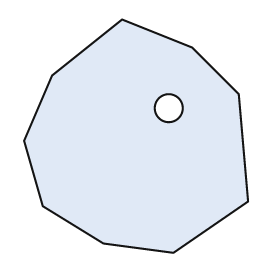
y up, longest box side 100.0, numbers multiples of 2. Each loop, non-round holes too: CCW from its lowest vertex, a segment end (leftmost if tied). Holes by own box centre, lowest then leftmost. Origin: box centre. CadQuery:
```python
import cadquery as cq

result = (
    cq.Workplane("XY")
    .moveTo(16.0, -50.0)
    .lineTo(48.0, -28.0)
    .lineTo(44.0, 18.0)
    .lineTo(24.0, 38.0)
    .lineTo(-6.0, 50.0)
    .lineTo(-36.0, 26.0)
    .lineTo(-48.0, -2.0)
    .lineTo(-40.0, -30.0)
    .lineTo(-14.0, -46.0)
    .close()
    .moveTo(14.0, 12.0)
    .circle(6.0)
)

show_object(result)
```